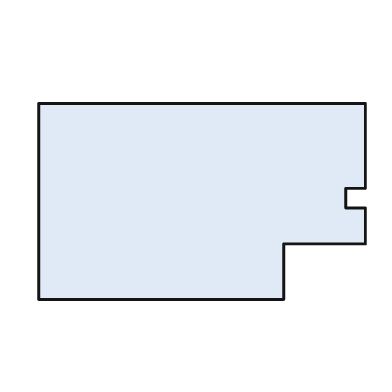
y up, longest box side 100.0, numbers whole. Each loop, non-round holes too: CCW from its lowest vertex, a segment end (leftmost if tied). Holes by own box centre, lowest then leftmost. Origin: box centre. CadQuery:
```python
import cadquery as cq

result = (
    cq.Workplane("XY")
    .moveTo(-50.0, -30.0)
    .lineTo(25.0, -30.0)
    .lineTo(25.0, -13.0)
    .lineTo(50.0, -13.0)
    .lineTo(50.0, -2.0)
    .lineTo(44.0, -2.0)
    .lineTo(44.0, 4.0)
    .lineTo(50.0, 4.0)
    .lineTo(50.0, 30.0)
    .lineTo(-50.0, 30.0)
    .close()
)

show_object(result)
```